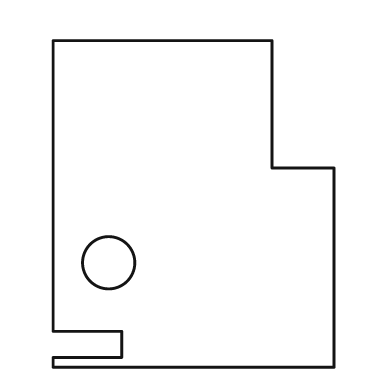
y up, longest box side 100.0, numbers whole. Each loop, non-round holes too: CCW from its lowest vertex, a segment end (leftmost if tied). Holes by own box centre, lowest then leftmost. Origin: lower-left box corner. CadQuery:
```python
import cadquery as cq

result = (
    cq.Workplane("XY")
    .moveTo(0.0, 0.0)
    .lineTo(86.0, 0.0)
    .lineTo(86.0, 61.0)
    .lineTo(67.0, 61.0)
    .lineTo(67.0, 100.0)
    .lineTo(0.0, 100.0)
    .lineTo(0.0, 11.0)
    .lineTo(21.0, 11.0)
    .lineTo(21.0, 3.0)
    .lineTo(0.0, 3.0)
    .close()
    .moveTo(17.0, 32.0)
    .circle(8.0)
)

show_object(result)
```